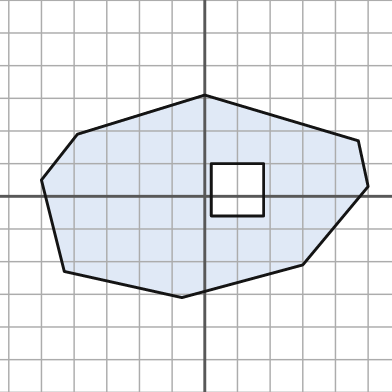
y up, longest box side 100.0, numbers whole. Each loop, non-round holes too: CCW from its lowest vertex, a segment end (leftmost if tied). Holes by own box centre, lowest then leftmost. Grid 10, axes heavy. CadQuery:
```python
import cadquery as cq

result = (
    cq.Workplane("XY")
    .moveTo(-7.0, -31.0)
    .lineTo(30.0, -21.0)
    .lineTo(50.0, 3.0)
    .lineTo(47.0, 17.0)
    .lineTo(0.0, 31.0)
    .lineTo(-39.0, 19.0)
    .lineTo(-50.0, 5.0)
    .lineTo(-43.0, -23.0)
    .close()
    .moveTo(2.0, -6.0)
    .lineTo(18.0, -6.0)
    .lineTo(18.0, 10.0)
    .lineTo(2.0, 10.0)
    .close()
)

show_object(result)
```